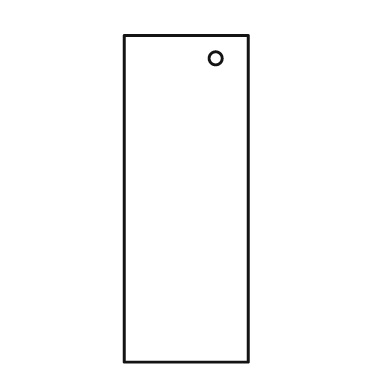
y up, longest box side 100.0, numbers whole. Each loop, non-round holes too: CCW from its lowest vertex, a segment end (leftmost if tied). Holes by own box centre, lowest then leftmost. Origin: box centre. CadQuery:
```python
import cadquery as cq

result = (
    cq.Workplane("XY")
    .moveTo(-19.0, -50.0)
    .lineTo(19.0, -50.0)
    .lineTo(19.0, 50.0)
    .lineTo(-19.0, 50.0)
    .close()
    .moveTo(9.0, 43.0)
    .circle(2.0)
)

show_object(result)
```